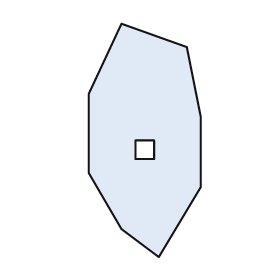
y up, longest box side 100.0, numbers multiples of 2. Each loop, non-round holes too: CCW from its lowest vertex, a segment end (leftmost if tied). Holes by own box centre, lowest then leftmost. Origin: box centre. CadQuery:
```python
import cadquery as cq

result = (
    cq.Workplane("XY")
    .moveTo(6.0, -50.0)
    .lineTo(24.0, -20.0)
    .lineTo(24.0, 10.0)
    .lineTo(18.0, 40.0)
    .lineTo(-10.0, 50.0)
    .lineTo(-24.0, 20.0)
    .lineTo(-24.0, -14.0)
    .lineTo(-10.0, -38.0)
    .close()
    .moveTo(-4.0, -8.0)
    .lineTo(4.0, -8.0)
    .lineTo(4.0, 0.0)
    .lineTo(-4.0, 0.0)
    .close()
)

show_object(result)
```